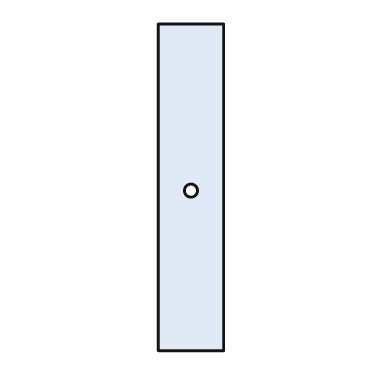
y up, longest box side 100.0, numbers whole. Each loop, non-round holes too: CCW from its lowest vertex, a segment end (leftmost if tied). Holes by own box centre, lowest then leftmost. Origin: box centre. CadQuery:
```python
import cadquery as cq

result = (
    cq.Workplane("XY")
    .moveTo(-10.0, -50.0)
    .lineTo(10.0, -50.0)
    .lineTo(10.0, 50.0)
    .lineTo(-10.0, 50.0)
    .close()
    .moveTo(0.0, -1.0)
    .circle(2.0)
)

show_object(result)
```